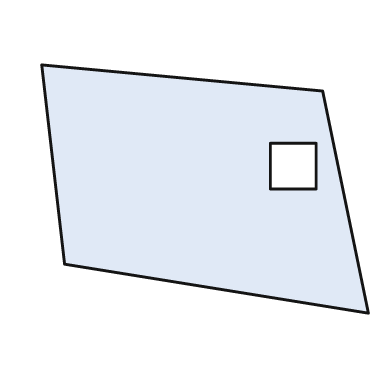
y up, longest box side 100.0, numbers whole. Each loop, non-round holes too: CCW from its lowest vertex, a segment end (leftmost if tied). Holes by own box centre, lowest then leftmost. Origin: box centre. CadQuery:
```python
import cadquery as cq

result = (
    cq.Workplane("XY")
    .moveTo(50.0, -38.0)
    .lineTo(36.0, 30.0)
    .lineTo(-50.0, 38.0)
    .lineTo(-43.0, -23.0)
    .close()
    .moveTo(20.0, 0.0)
    .lineTo(34.0, 0.0)
    .lineTo(34.0, 14.0)
    .lineTo(20.0, 14.0)
    .close()
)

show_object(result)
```